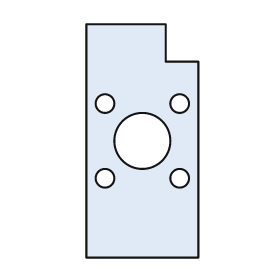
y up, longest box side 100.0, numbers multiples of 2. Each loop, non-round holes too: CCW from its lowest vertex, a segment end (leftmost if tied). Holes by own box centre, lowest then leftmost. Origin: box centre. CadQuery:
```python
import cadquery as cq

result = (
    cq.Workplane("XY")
    .moveTo(-24.0, -50.0)
    .lineTo(24.0, -50.0)
    .lineTo(24.0, 34.0)
    .lineTo(10.0, 34.0)
    .lineTo(10.0, 50.0)
    .lineTo(-24.0, 50.0)
    .close()
    .moveTo(-16.0, -16.0)
    .circle(4.0)
    .moveTo(16.0, -16.0)
    .circle(4.0)
    .moveTo(0.0, 0.0)
    .circle(12.0)
    .moveTo(-16.0, 16.0)
    .circle(4.0)
    .moveTo(16.0, 16.0)
    .circle(4.0)
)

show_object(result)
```